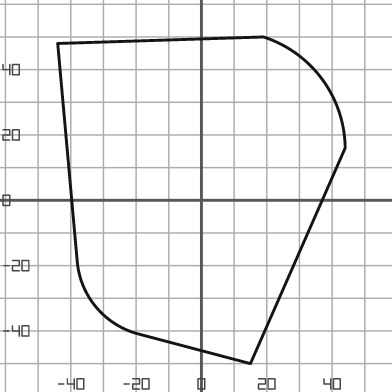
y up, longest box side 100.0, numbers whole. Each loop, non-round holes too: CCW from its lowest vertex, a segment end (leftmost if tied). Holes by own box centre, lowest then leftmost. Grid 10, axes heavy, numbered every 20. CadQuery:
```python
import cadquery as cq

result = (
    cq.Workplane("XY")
    .moveTo(15.0, -50.0)
    .lineTo(44.0, 16.0)
    .threePointArc((37.0, 37.0), (19.0, 50.0))
    .lineTo(-44.0, 48.0)
    .lineTo(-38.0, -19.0)
    .threePointArc((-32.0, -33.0), (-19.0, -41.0))
    .close()
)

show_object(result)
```